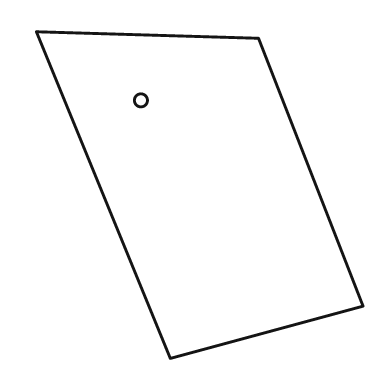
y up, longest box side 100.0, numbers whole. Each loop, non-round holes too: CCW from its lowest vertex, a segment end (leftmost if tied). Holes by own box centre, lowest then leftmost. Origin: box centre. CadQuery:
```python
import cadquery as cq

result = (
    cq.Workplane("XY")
    .moveTo(-9.0, -50.0)
    .lineTo(50.0, -34.0)
    .lineTo(18.0, 48.0)
    .lineTo(-50.0, 50.0)
    .close()
    .moveTo(-18.0, 29.0)
    .circle(2.0)
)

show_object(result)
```